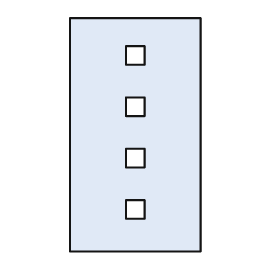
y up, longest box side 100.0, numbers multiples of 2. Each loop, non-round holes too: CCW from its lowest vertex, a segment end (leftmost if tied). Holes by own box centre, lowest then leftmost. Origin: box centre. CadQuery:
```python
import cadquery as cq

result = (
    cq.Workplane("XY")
    .moveTo(-28.0, -50.0)
    .lineTo(28.0, -50.0)
    .lineTo(28.0, 50.0)
    .lineTo(-28.0, 50.0)
    .close()
    .moveTo(-4.0, -36.0)
    .lineTo(4.0, -36.0)
    .lineTo(4.0, -28.0)
    .lineTo(-4.0, -28.0)
    .close()
    .moveTo(-4.0, -14.0)
    .lineTo(4.0, -14.0)
    .lineTo(4.0, -6.0)
    .lineTo(-4.0, -6.0)
    .close()
    .moveTo(-4.0, 8.0)
    .lineTo(4.0, 8.0)
    .lineTo(4.0, 16.0)
    .lineTo(-4.0, 16.0)
    .close()
    .moveTo(-4.0, 30.0)
    .lineTo(4.0, 30.0)
    .lineTo(4.0, 38.0)
    .lineTo(-4.0, 38.0)
    .close()
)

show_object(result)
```